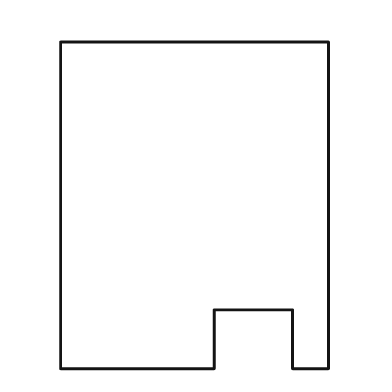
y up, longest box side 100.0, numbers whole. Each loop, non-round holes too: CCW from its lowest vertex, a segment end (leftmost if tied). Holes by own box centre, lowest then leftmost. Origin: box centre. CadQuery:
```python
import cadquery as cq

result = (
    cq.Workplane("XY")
    .moveTo(-41.0, -50.0)
    .lineTo(6.0, -50.0)
    .lineTo(6.0, -32.0)
    .lineTo(30.0, -32.0)
    .lineTo(30.0, -50.0)
    .lineTo(41.0, -50.0)
    .lineTo(41.0, 50.0)
    .lineTo(-41.0, 50.0)
    .close()
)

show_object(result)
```